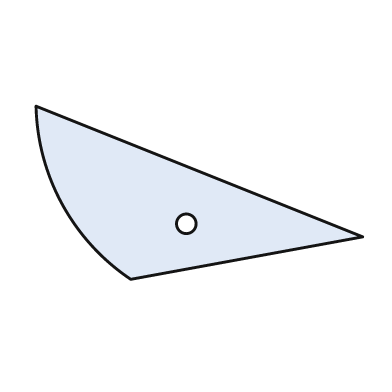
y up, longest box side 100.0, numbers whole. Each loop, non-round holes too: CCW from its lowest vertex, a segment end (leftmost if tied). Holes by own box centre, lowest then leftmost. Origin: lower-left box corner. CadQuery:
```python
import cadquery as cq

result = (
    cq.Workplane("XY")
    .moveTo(29.0, 0.0)
    .lineTo(100.0, 13.0)
    .lineTo(0.0, 53.0)
    .threePointArc((8.0, 23.0), (29.0, 0.0))
    .close()
    .moveTo(46.0, 17.0)
    .circle(3.0)
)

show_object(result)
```